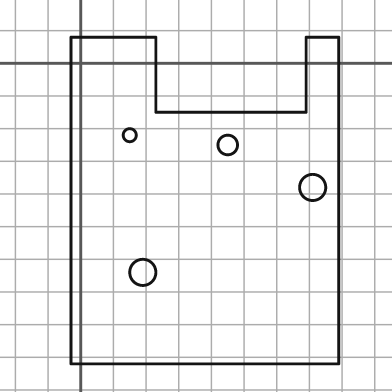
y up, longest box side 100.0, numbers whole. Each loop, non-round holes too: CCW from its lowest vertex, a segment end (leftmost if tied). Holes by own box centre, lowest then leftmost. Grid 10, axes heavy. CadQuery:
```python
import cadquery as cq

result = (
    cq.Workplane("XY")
    .moveTo(-3.0, -92.0)
    .lineTo(79.0, -92.0)
    .lineTo(79.0, 8.0)
    .lineTo(69.0, 8.0)
    .lineTo(69.0, -15.0)
    .lineTo(23.0, -15.0)
    .lineTo(23.0, 8.0)
    .lineTo(-3.0, 8.0)
    .close()
    .moveTo(19.0, -64.0)
    .circle(4.0)
    .moveTo(71.0, -38.0)
    .circle(4.0)
    .moveTo(45.0, -25.0)
    .circle(3.0)
    .moveTo(15.0, -22.0)
    .circle(2.0)
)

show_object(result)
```